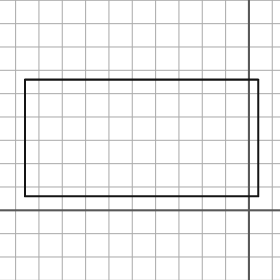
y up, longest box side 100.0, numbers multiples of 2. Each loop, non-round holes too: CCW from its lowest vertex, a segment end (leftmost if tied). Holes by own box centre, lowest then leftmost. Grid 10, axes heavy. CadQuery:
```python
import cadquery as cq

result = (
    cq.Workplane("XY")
    .moveTo(-96.0, 6.0)
    .lineTo(4.0, 6.0)
    .lineTo(4.0, 56.0)
    .lineTo(-96.0, 56.0)
    .close()
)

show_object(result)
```